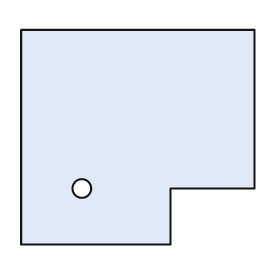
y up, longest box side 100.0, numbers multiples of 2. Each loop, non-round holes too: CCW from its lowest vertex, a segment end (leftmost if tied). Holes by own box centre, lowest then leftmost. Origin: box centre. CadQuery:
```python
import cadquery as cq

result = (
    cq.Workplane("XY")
    .moveTo(-50.0, -46.0)
    .lineTo(14.0, -46.0)
    .lineTo(14.0, -22.0)
    .lineTo(50.0, -22.0)
    .lineTo(50.0, 46.0)
    .lineTo(-50.0, 46.0)
    .close()
    .moveTo(-24.0, -22.0)
    .circle(4.0)
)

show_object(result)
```